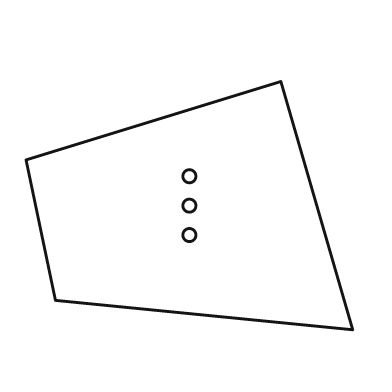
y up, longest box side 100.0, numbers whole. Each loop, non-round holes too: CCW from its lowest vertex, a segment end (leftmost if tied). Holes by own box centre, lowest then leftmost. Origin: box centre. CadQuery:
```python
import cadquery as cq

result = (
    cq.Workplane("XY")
    .moveTo(50.0, -38.0)
    .lineTo(28.0, 38.0)
    .lineTo(-50.0, 14.0)
    .lineTo(-41.0, -29.0)
    .close()
    .moveTo(0.0, -9.0)
    .circle(2.0)
    .moveTo(0.0, 0.0)
    .circle(2.0)
    .moveTo(0.0, 9.0)
    .circle(2.0)
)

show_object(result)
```